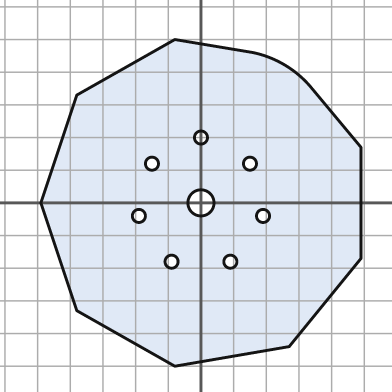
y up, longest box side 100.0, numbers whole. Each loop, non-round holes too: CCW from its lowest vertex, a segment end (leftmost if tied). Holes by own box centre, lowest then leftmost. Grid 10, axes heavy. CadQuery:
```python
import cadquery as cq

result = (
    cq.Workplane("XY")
    .moveTo(-8.0, -50.0)
    .lineTo(27.0, -44.0)
    .lineTo(49.0, -17.0)
    .lineTo(49.0, 17.0)
    .lineTo(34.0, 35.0)
    .threePointArc((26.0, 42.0), (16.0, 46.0))
    .lineTo(-8.0, 50.0)
    .lineTo(-38.0, 33.0)
    .lineTo(-49.0, 0.0)
    .lineTo(-38.0, -33.0)
    .close()
    .moveTo(-9.0, -18.0)
    .circle(2.0)
    .moveTo(9.0, -18.0)
    .circle(2.0)
    .moveTo(-19.0, -4.0)
    .circle(2.0)
    .moveTo(19.0, -4.0)
    .circle(2.0)
    .moveTo(0.0, 0.0)
    .circle(4.0)
    .moveTo(-15.0, 12.0)
    .circle(2.0)
    .moveTo(15.0, 12.0)
    .circle(2.0)
    .moveTo(0.0, 20.0)
    .circle(2.0)
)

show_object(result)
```